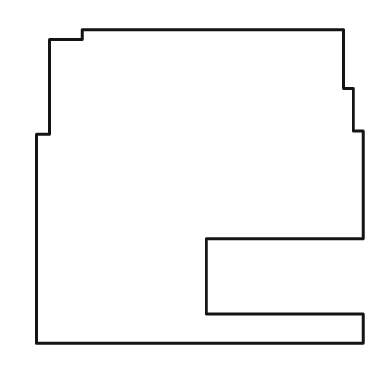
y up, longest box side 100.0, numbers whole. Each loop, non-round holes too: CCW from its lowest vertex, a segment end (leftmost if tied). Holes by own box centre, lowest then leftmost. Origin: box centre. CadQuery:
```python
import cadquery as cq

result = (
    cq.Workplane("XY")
    .moveTo(-50.0, -48.0)
    .lineTo(50.0, -48.0)
    .lineTo(50.0, -39.0)
    .lineTo(2.0, -39.0)
    .lineTo(2.0, -16.0)
    .lineTo(50.0, -16.0)
    .lineTo(50.0, 17.0)
    .lineTo(47.0, 17.0)
    .lineTo(47.0, 30.0)
    .lineTo(44.0, 30.0)
    .lineTo(44.0, 48.0)
    .lineTo(-36.0, 48.0)
    .lineTo(-36.0, 45.0)
    .lineTo(-46.0, 45.0)
    .lineTo(-46.0, 16.0)
    .lineTo(-50.0, 16.0)
    .close()
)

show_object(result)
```